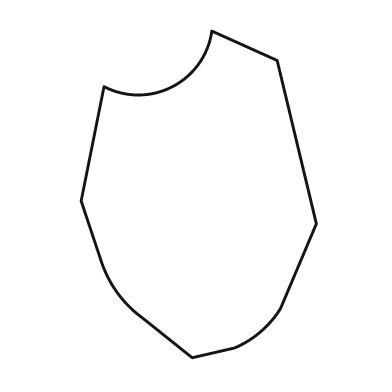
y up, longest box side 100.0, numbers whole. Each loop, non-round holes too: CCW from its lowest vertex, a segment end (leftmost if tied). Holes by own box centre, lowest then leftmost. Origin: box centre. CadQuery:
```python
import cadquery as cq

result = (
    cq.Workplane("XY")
    .moveTo(-2.0, -50.0)
    .lineTo(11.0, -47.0)
    .threePointArc((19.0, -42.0), (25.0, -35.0))
    .lineTo(36.0, -9.0)
    .lineTo(24.0, 41.0)
    .lineTo(4.0, 50.0)
    .threePointArc((-8.0, 33.0), (-29.0, 33.0))
    .lineTo(-36.0, -2.0)
    .lineTo(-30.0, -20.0)
    .threePointArc((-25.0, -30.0), (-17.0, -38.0))
    .close()
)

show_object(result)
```